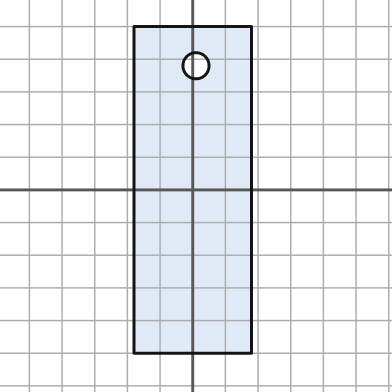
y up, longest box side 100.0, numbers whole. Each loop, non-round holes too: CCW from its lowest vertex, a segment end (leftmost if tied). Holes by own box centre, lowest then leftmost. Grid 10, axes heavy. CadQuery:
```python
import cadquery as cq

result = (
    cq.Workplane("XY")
    .moveTo(-18.0, -50.0)
    .lineTo(18.0, -50.0)
    .lineTo(18.0, 50.0)
    .lineTo(-18.0, 50.0)
    .close()
    .moveTo(1.0, 38.0)
    .circle(4.0)
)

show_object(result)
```